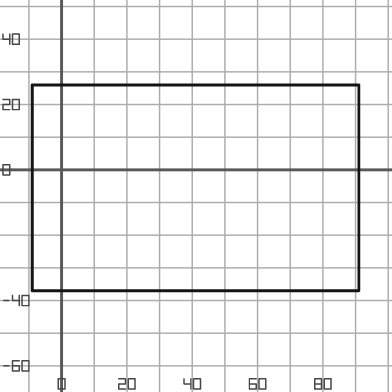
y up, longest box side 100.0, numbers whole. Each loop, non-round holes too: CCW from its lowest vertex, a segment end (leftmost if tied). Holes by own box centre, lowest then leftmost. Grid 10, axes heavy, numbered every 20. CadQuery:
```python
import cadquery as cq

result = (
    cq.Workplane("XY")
    .moveTo(-9.0, -37.0)
    .lineTo(91.0, -37.0)
    .lineTo(91.0, 26.0)
    .lineTo(-9.0, 26.0)
    .close()
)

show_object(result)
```